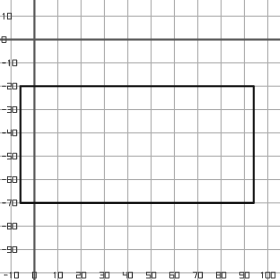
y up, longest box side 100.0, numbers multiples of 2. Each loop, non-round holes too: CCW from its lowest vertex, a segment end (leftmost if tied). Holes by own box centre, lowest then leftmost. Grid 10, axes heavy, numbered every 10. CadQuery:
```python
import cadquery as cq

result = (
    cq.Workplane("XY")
    .moveTo(-6.0, -70.0)
    .lineTo(94.0, -70.0)
    .lineTo(94.0, -20.0)
    .lineTo(-6.0, -20.0)
    .close()
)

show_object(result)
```